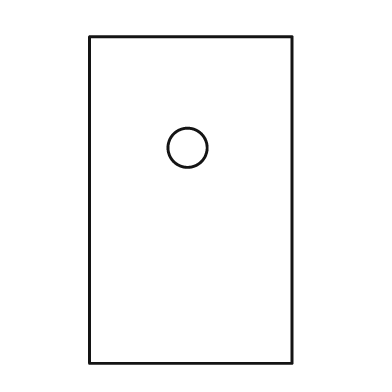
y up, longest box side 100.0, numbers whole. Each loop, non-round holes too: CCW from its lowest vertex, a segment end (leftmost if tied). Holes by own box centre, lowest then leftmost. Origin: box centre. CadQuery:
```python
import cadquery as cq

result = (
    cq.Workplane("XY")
    .moveTo(-31.0, -50.0)
    .lineTo(31.0, -50.0)
    .lineTo(31.0, 50.0)
    .lineTo(-31.0, 50.0)
    .close()
    .moveTo(-1.0, 16.0)
    .circle(6.0)
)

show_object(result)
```